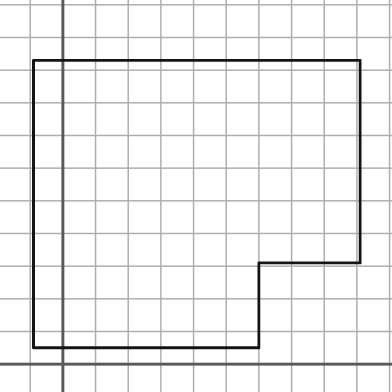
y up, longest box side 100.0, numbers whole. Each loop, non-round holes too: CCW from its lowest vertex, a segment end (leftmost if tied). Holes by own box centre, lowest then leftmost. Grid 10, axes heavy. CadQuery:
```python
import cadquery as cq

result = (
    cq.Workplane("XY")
    .moveTo(-9.0, 5.0)
    .lineTo(60.0, 5.0)
    .lineTo(60.0, 31.0)
    .lineTo(91.0, 31.0)
    .lineTo(91.0, 93.0)
    .lineTo(-9.0, 93.0)
    .close()
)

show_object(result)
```